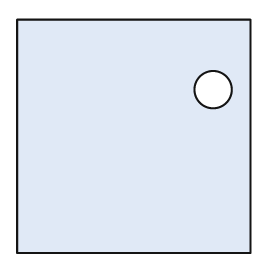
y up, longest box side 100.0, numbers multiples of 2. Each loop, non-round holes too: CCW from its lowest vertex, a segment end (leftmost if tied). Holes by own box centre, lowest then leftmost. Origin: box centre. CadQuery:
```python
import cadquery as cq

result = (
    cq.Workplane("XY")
    .moveTo(-50.0, -50.0)
    .lineTo(50.0, -50.0)
    .lineTo(50.0, 50.0)
    .lineTo(-50.0, 50.0)
    .close()
    .moveTo(34.0, 20.0)
    .circle(8.0)
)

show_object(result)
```